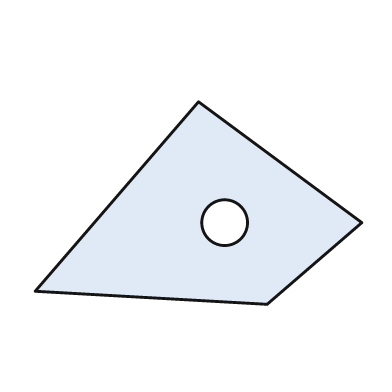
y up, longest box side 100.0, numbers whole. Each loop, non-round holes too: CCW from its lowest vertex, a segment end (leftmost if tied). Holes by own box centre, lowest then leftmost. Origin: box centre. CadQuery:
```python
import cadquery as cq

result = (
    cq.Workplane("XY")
    .moveTo(21.0, -31.0)
    .lineTo(50.0, -6.0)
    .lineTo(0.0, 31.0)
    .lineTo(-50.0, -27.0)
    .close()
    .moveTo(8.0, -6.0)
    .circle(7.0)
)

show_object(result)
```